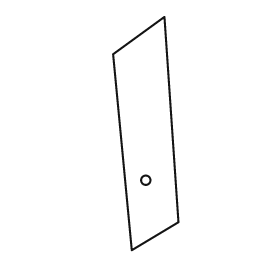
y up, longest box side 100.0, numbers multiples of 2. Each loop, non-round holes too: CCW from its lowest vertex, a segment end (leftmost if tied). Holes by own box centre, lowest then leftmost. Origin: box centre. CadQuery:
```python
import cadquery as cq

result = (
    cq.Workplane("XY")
    .moveTo(-6.0, -50.0)
    .lineTo(14.0, -38.0)
    .lineTo(8.0, 50.0)
    .lineTo(-14.0, 34.0)
    .close()
    .moveTo(0.0, -20.0)
    .circle(2.0)
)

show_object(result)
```